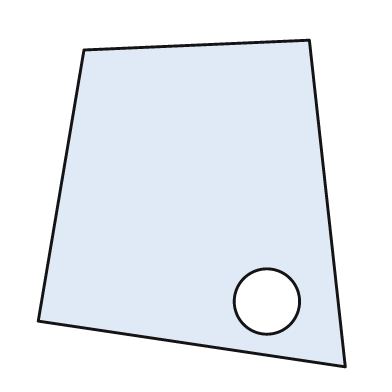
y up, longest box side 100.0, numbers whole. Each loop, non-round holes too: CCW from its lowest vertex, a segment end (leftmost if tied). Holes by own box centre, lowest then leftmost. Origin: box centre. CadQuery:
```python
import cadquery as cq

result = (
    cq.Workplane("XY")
    .moveTo(47.0, -50.0)
    .lineTo(36.0, 50.0)
    .lineTo(-33.0, 47.0)
    .lineTo(-47.0, -36.0)
    .close()
    .moveTo(23.0, -30.0)
    .circle(10.0)
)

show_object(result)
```